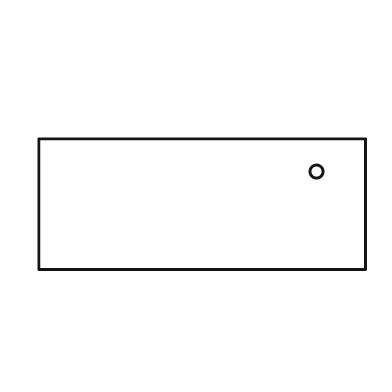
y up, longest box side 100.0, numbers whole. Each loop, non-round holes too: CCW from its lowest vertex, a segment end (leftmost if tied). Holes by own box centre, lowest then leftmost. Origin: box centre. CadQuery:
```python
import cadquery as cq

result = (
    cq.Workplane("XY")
    .moveTo(-50.0, -20.0)
    .lineTo(50.0, -20.0)
    .lineTo(50.0, 20.0)
    .lineTo(-50.0, 20.0)
    .close()
    .moveTo(35.0, 10.0)
    .circle(2.0)
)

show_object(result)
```